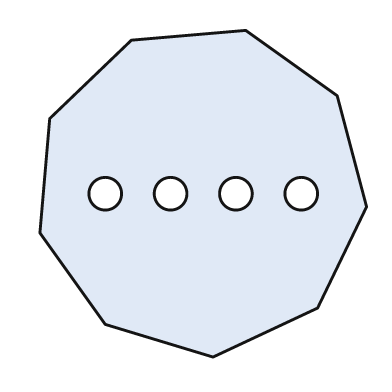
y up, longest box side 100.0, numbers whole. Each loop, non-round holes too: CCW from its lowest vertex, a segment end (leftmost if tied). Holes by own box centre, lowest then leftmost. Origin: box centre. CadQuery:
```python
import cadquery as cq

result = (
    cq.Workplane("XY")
    .moveTo(3.0, -50.0)
    .lineTo(35.0, -35.0)
    .lineTo(50.0, -4.0)
    .lineTo(41.0, 30.0)
    .lineTo(13.0, 50.0)
    .lineTo(-22.0, 47.0)
    .lineTo(-47.0, 23.0)
    .lineTo(-50.0, -12.0)
    .lineTo(-30.0, -40.0)
    .close()
    .moveTo(-30.0, 0.0)
    .circle(5.0)
    .moveTo(-10.0, 0.0)
    .circle(5.0)
    .moveTo(10.0, 0.0)
    .circle(5.0)
    .moveTo(30.0, 0.0)
    .circle(5.0)
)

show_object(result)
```